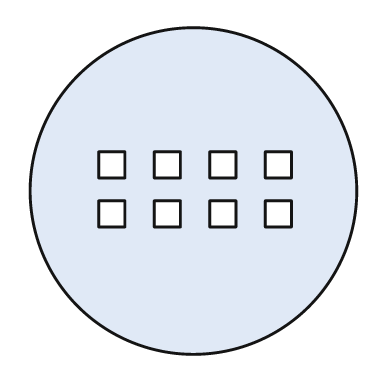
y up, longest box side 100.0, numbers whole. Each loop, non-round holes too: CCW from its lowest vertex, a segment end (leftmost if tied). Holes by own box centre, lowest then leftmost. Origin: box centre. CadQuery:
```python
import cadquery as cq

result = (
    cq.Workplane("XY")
    .moveTo(0.0, 0.0)
    .circle(50.0)
    .moveTo(-29.0, -11.0)
    .lineTo(-21.0, -11.0)
    .lineTo(-21.0, -3.0)
    .lineTo(-29.0, -3.0)
    .close()
    .moveTo(-12.0, -11.0)
    .lineTo(-4.0, -11.0)
    .lineTo(-4.0, -3.0)
    .lineTo(-12.0, -3.0)
    .close()
    .moveTo(5.0, -11.0)
    .lineTo(13.0, -11.0)
    .lineTo(13.0, -3.0)
    .lineTo(5.0, -3.0)
    .close()
    .moveTo(22.0, -11.0)
    .lineTo(30.0, -11.0)
    .lineTo(30.0, -3.0)
    .lineTo(22.0, -3.0)
    .close()
    .moveTo(-29.0, 4.0)
    .lineTo(-21.0, 4.0)
    .lineTo(-21.0, 12.0)
    .lineTo(-29.0, 12.0)
    .close()
    .moveTo(-12.0, 4.0)
    .lineTo(-4.0, 4.0)
    .lineTo(-4.0, 12.0)
    .lineTo(-12.0, 12.0)
    .close()
    .moveTo(5.0, 4.0)
    .lineTo(13.0, 4.0)
    .lineTo(13.0, 12.0)
    .lineTo(5.0, 12.0)
    .close()
    .moveTo(22.0, 4.0)
    .lineTo(30.0, 4.0)
    .lineTo(30.0, 12.0)
    .lineTo(22.0, 12.0)
    .close()
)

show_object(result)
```